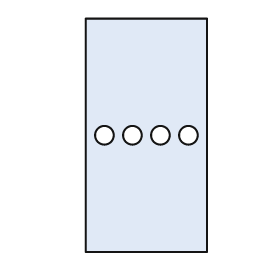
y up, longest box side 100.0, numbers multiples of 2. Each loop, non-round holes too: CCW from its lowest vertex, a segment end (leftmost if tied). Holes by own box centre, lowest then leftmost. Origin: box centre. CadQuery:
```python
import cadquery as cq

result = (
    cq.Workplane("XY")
    .moveTo(-26.0, -50.0)
    .lineTo(26.0, -50.0)
    .lineTo(26.0, 50.0)
    .lineTo(-26.0, 50.0)
    .close()
    .moveTo(-18.0, 0.0)
    .circle(4.0)
    .moveTo(-6.0, 0.0)
    .circle(4.0)
    .moveTo(6.0, 0.0)
    .circle(4.0)
    .moveTo(18.0, 0.0)
    .circle(4.0)
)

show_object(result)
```